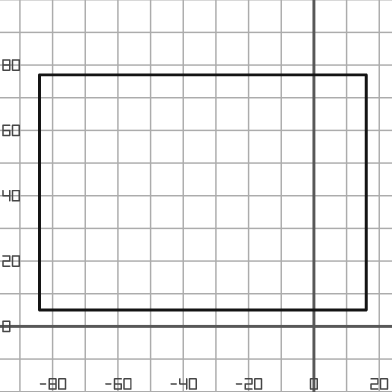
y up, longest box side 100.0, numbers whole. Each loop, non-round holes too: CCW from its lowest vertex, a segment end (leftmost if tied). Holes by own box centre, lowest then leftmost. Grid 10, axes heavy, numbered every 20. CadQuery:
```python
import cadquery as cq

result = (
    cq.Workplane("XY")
    .moveTo(-84.0, 5.0)
    .lineTo(16.0, 5.0)
    .lineTo(16.0, 77.0)
    .lineTo(-84.0, 77.0)
    .close()
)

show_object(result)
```